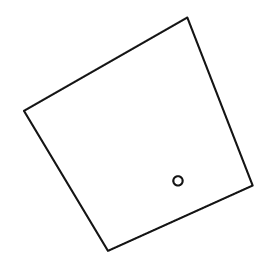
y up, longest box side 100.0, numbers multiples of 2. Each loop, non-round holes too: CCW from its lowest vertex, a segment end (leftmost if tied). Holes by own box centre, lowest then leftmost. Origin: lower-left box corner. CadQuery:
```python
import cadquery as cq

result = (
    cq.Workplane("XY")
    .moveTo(36.0, 0.0)
    .lineTo(98.0, 28.0)
    .lineTo(70.0, 100.0)
    .lineTo(0.0, 60.0)
    .close()
    .moveTo(66.0, 30.0)
    .circle(2.0)
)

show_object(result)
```